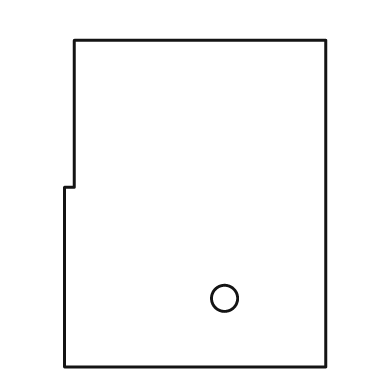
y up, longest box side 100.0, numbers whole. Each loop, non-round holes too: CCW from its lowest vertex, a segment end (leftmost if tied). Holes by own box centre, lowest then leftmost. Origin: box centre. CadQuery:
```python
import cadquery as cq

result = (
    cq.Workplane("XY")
    .moveTo(-40.0, -50.0)
    .lineTo(40.0, -50.0)
    .lineTo(40.0, 50.0)
    .lineTo(-37.0, 50.0)
    .lineTo(-37.0, 5.0)
    .lineTo(-40.0, 5.0)
    .close()
    .moveTo(9.0, -29.0)
    .circle(4.0)
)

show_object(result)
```